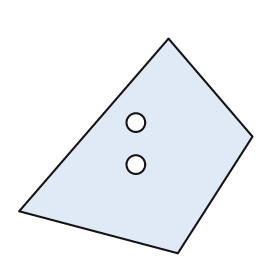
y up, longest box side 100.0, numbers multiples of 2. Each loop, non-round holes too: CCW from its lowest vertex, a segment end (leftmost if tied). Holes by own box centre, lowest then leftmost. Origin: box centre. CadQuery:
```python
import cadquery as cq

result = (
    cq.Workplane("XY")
    .moveTo(18.0, -46.0)
    .lineTo(50.0, 4.0)
    .lineTo(14.0, 46.0)
    .lineTo(-50.0, -28.0)
    .close()
    .moveTo(0.0, -8.0)
    .circle(4.0)
    .moveTo(0.0, 10.0)
    .circle(4.0)
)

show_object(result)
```